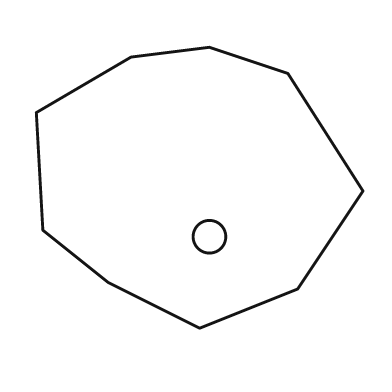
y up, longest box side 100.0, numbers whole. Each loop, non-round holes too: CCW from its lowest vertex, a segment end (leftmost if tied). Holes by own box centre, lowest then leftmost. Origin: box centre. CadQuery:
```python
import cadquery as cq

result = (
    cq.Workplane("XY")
    .moveTo(0.0, -43.0)
    .lineTo(30.0, -31.0)
    .lineTo(50.0, -1.0)
    .lineTo(27.0, 35.0)
    .lineTo(3.0, 43.0)
    .lineTo(-21.0, 40.0)
    .lineTo(-50.0, 23.0)
    .lineTo(-48.0, -13.0)
    .lineTo(-28.0, -29.0)
    .close()
    .moveTo(3.0, -15.0)
    .circle(5.0)
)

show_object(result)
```